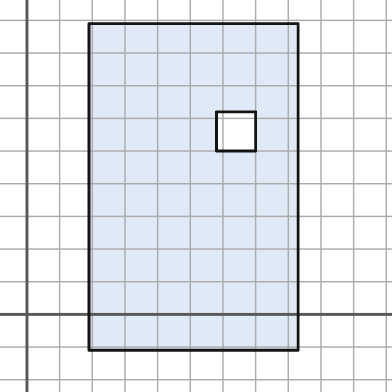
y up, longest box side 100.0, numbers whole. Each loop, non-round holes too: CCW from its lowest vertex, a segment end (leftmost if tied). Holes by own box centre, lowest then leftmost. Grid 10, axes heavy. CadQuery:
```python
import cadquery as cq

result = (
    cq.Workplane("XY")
    .moveTo(19.0, -11.0)
    .lineTo(83.0, -11.0)
    .lineTo(83.0, 89.0)
    .lineTo(19.0, 89.0)
    .close()
    .moveTo(58.0, 50.0)
    .lineTo(70.0, 50.0)
    .lineTo(70.0, 62.0)
    .lineTo(58.0, 62.0)
    .close()
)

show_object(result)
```